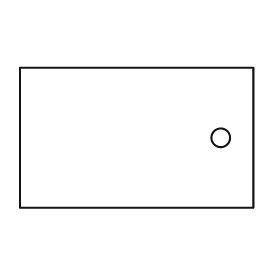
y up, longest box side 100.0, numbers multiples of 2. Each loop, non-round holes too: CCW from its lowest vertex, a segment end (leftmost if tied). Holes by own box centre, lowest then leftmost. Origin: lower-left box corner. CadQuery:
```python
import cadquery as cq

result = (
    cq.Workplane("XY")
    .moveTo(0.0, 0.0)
    .lineTo(100.0, 0.0)
    .lineTo(100.0, 60.0)
    .lineTo(0.0, 60.0)
    .close()
    .moveTo(86.0, 30.0)
    .circle(4.0)
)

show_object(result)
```